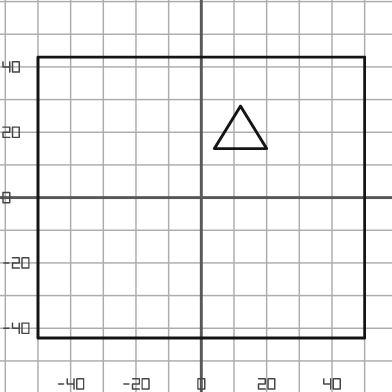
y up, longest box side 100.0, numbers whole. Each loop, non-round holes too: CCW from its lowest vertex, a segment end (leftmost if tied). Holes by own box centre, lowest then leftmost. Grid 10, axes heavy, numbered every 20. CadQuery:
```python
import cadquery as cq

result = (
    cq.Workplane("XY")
    .moveTo(-50.0, -43.0)
    .lineTo(50.0, -43.0)
    .lineTo(50.0, 43.0)
    .lineTo(-50.0, 43.0)
    .close()
    .moveTo(4.0, 15.0)
    .lineTo(20.0, 15.0)
    .lineTo(12.0, 28.0)
    .close()
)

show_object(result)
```